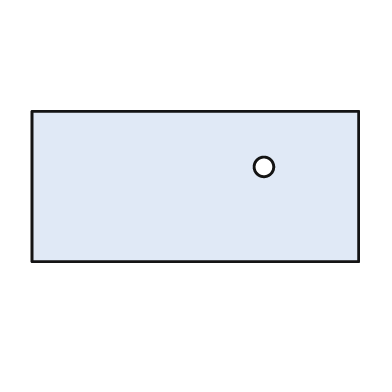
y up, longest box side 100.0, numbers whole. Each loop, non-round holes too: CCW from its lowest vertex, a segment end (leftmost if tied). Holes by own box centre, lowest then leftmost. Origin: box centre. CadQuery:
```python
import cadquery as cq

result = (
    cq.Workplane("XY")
    .moveTo(-50.0, -23.0)
    .lineTo(50.0, -23.0)
    .lineTo(50.0, 23.0)
    .lineTo(-50.0, 23.0)
    .close()
    .moveTo(21.0, 6.0)
    .circle(3.0)
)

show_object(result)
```